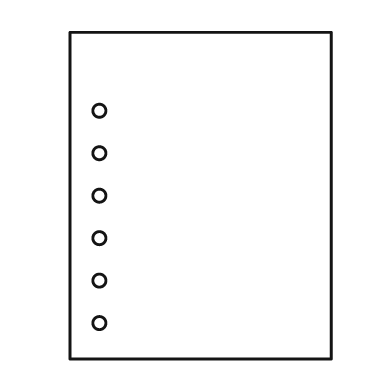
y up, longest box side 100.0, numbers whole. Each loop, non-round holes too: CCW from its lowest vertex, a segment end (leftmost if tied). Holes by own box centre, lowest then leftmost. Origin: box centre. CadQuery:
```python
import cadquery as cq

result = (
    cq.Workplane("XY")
    .moveTo(-40.0, -50.0)
    .lineTo(40.0, -50.0)
    .lineTo(40.0, 50.0)
    .lineTo(-40.0, 50.0)
    .close()
    .moveTo(-31.0, -39.0)
    .circle(2.0)
    .moveTo(-31.0, -26.0)
    .circle(2.0)
    .moveTo(-31.0, -13.0)
    .circle(2.0)
    .moveTo(-31.0, 0.0)
    .circle(2.0)
    .moveTo(-31.0, 13.0)
    .circle(2.0)
    .moveTo(-31.0, 26.0)
    .circle(2.0)
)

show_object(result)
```